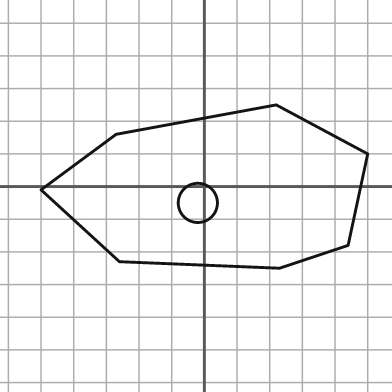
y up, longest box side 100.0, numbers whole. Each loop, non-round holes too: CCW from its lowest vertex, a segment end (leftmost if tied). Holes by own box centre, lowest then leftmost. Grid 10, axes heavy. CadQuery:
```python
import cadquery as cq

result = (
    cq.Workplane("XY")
    .moveTo(23.0, -25.0)
    .lineTo(44.0, -18.0)
    .lineTo(50.0, 10.0)
    .lineTo(22.0, 25.0)
    .lineTo(-27.0, 16.0)
    .lineTo(-50.0, -1.0)
    .lineTo(-26.0, -23.0)
    .close()
    .moveTo(-2.0, -5.0)
    .circle(6.0)
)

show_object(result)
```